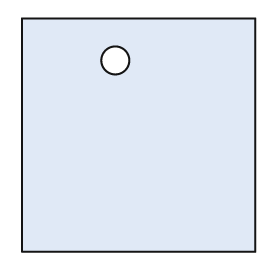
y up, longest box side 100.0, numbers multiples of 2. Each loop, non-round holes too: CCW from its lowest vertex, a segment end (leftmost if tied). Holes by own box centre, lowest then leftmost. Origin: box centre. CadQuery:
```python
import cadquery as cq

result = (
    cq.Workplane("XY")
    .moveTo(-50.0, -50.0)
    .lineTo(50.0, -50.0)
    .lineTo(50.0, 50.0)
    .lineTo(-50.0, 50.0)
    .close()
    .moveTo(-10.0, 32.0)
    .circle(6.0)
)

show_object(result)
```